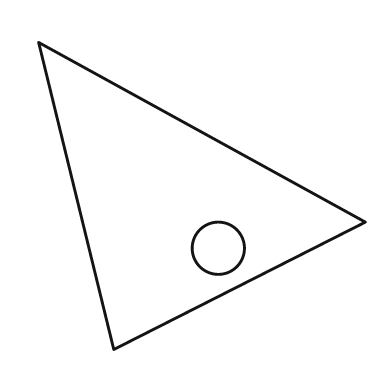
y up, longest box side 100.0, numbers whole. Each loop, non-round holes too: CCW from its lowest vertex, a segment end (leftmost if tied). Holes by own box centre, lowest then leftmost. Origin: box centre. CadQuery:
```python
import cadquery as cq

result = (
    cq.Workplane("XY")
    .moveTo(-27.0, -47.0)
    .lineTo(50.0, -8.0)
    .lineTo(-50.0, 47.0)
    .close()
    .moveTo(5.0, -16.0)
    .circle(8.0)
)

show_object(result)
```